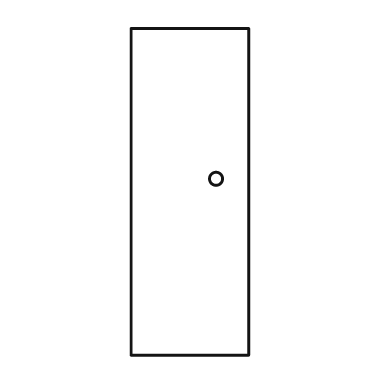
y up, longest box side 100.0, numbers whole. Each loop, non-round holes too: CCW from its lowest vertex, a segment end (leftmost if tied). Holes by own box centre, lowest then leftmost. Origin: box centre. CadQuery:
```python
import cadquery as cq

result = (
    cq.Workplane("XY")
    .moveTo(-18.0, -50.0)
    .lineTo(18.0, -50.0)
    .lineTo(18.0, 50.0)
    .lineTo(-18.0, 50.0)
    .close()
    .moveTo(8.0, 4.0)
    .circle(2.0)
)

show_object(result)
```